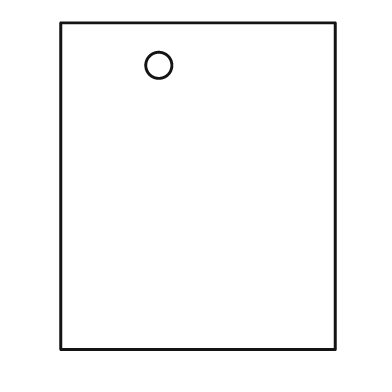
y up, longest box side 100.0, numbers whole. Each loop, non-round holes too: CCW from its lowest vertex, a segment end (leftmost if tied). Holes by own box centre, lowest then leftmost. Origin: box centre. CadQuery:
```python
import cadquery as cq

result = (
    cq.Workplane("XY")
    .moveTo(-42.0, -50.0)
    .lineTo(42.0, -50.0)
    .lineTo(42.0, 50.0)
    .lineTo(-42.0, 50.0)
    .close()
    .moveTo(-12.0, 37.0)
    .circle(4.0)
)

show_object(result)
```